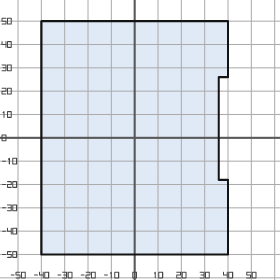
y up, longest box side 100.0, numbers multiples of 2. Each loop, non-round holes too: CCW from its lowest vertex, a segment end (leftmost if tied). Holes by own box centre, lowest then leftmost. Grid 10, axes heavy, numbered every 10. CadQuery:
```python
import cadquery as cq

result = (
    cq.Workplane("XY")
    .moveTo(-40.0, -50.0)
    .lineTo(40.0, -50.0)
    .lineTo(40.0, -18.0)
    .lineTo(36.0, -18.0)
    .lineTo(36.0, 26.0)
    .lineTo(40.0, 26.0)
    .lineTo(40.0, 50.0)
    .lineTo(-40.0, 50.0)
    .close()
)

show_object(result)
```